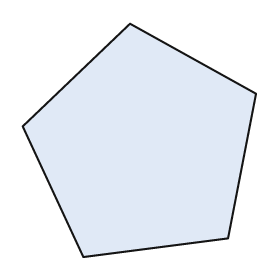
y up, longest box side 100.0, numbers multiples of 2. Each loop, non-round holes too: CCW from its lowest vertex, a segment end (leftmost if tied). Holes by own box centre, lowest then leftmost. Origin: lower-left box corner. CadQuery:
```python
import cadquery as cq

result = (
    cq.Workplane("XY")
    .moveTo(26.0, 0.0)
    .lineTo(88.0, 8.0)
    .lineTo(100.0, 70.0)
    .lineTo(46.0, 100.0)
    .lineTo(0.0, 56.0)
    .close()
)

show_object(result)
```